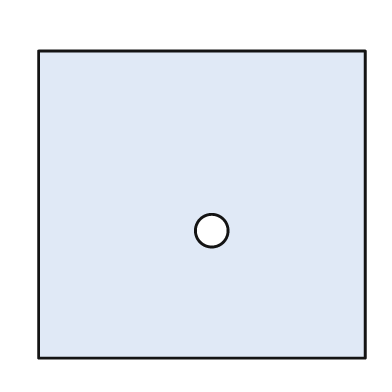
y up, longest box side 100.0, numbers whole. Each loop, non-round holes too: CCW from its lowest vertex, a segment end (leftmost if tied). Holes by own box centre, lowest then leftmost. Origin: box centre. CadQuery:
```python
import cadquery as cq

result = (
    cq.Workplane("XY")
    .moveTo(-50.0, -47.0)
    .lineTo(50.0, -47.0)
    .lineTo(50.0, 47.0)
    .lineTo(-50.0, 47.0)
    .close()
    .moveTo(3.0, -8.0)
    .circle(5.0)
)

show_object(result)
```